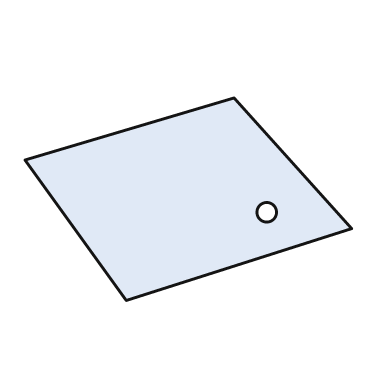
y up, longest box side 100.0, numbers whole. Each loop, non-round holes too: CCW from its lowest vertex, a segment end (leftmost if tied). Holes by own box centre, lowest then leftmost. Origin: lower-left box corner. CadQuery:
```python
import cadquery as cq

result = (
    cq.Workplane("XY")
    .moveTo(31.0, 0.0)
    .lineTo(100.0, 22.0)
    .lineTo(64.0, 62.0)
    .lineTo(0.0, 43.0)
    .close()
    .moveTo(74.0, 27.0)
    .circle(3.0)
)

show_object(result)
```